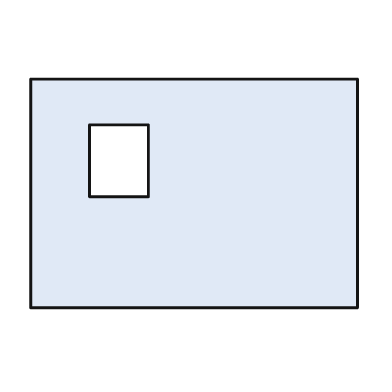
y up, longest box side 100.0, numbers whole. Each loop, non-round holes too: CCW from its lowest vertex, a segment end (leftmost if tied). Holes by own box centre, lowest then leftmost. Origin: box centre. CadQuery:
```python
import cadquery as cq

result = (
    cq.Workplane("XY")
    .moveTo(-50.0, -35.0)
    .lineTo(50.0, -35.0)
    .lineTo(50.0, 35.0)
    .lineTo(-50.0, 35.0)
    .close()
    .moveTo(-32.0, -1.0)
    .lineTo(-14.0, -1.0)
    .lineTo(-14.0, 21.0)
    .lineTo(-32.0, 21.0)
    .close()
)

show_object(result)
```